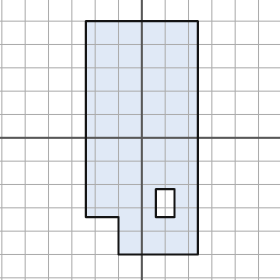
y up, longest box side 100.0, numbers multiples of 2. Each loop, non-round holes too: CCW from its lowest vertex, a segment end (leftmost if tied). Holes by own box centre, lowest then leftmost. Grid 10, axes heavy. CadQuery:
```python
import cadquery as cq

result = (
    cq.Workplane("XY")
    .moveTo(-10.0, -50.0)
    .lineTo(24.0, -50.0)
    .lineTo(24.0, 50.0)
    .lineTo(-24.0, 50.0)
    .lineTo(-24.0, -34.0)
    .lineTo(-10.0, -34.0)
    .close()
    .moveTo(6.0, -34.0)
    .lineTo(14.0, -34.0)
    .lineTo(14.0, -22.0)
    .lineTo(6.0, -22.0)
    .close()
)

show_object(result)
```